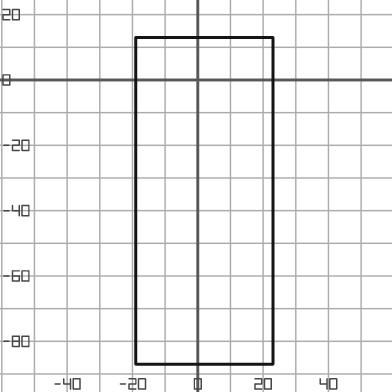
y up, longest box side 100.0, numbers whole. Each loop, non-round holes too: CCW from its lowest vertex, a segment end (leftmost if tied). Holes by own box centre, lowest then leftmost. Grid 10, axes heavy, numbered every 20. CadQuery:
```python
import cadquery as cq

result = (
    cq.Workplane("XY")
    .moveTo(-19.0, -87.0)
    .lineTo(23.0, -87.0)
    .lineTo(23.0, 13.0)
    .lineTo(-19.0, 13.0)
    .close()
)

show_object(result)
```